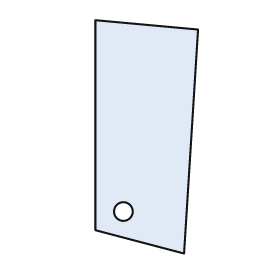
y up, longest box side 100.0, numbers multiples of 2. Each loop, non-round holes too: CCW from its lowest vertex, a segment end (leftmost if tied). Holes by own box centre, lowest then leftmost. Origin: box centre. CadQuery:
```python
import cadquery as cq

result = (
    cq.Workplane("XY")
    .moveTo(16.0, -50.0)
    .lineTo(22.0, 46.0)
    .lineTo(-22.0, 50.0)
    .lineTo(-22.0, -40.0)
    .close()
    .moveTo(-10.0, -32.0)
    .circle(4.0)
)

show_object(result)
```